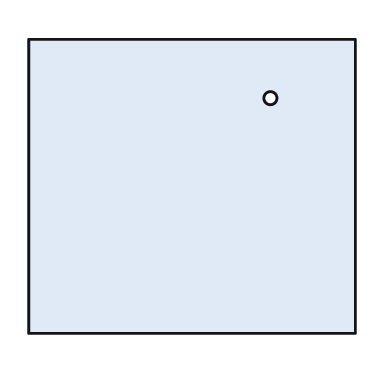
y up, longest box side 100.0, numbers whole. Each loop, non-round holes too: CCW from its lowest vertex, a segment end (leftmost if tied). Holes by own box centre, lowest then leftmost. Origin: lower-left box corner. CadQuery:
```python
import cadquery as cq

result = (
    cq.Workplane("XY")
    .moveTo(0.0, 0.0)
    .lineTo(100.0, 0.0)
    .lineTo(100.0, 90.0)
    .lineTo(0.0, 90.0)
    .close()
    .moveTo(74.0, 72.0)
    .circle(2.0)
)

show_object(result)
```